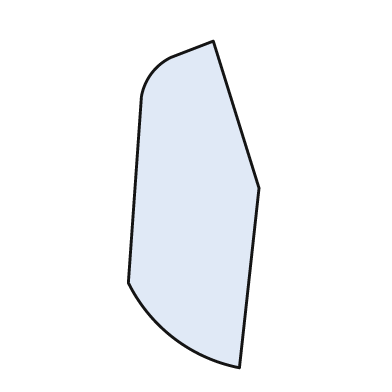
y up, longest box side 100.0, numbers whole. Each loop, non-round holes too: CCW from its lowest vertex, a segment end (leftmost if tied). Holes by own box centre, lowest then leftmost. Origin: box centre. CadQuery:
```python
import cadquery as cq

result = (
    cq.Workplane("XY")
    .moveTo(14.0, -50.0)
    .lineTo(20.0, 5.0)
    .lineTo(6.0, 50.0)
    .lineTo(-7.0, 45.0)
    .threePointArc((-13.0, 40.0), (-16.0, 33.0))
    .lineTo(-20.0, -24.0)
    .threePointArc((-6.0, -41.0), (14.0, -50.0))
    .close()
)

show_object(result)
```